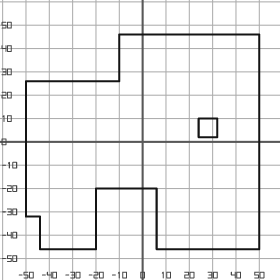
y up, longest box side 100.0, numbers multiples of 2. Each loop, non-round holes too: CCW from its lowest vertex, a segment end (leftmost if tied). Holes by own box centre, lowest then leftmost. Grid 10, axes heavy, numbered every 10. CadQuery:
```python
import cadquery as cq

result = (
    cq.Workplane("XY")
    .moveTo(-44.0, -46.0)
    .lineTo(-20.0, -46.0)
    .lineTo(-20.0, -20.0)
    .lineTo(6.0, -20.0)
    .lineTo(6.0, -46.0)
    .lineTo(50.0, -46.0)
    .lineTo(50.0, 46.0)
    .lineTo(-10.0, 46.0)
    .lineTo(-10.0, 26.0)
    .lineTo(-50.0, 26.0)
    .lineTo(-50.0, -32.0)
    .lineTo(-44.0, -32.0)
    .close()
    .moveTo(24.0, 2.0)
    .lineTo(32.0, 2.0)
    .lineTo(32.0, 10.0)
    .lineTo(24.0, 10.0)
    .close()
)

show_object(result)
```